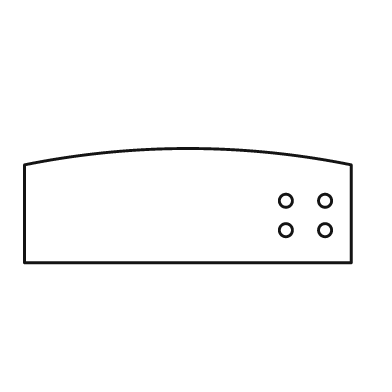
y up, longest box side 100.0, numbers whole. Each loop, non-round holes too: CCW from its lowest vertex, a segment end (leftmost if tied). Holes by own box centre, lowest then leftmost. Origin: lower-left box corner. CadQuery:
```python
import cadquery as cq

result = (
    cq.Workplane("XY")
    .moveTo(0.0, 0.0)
    .lineTo(100.0, 0.0)
    .lineTo(100.0, 30.0)
    .threePointArc((50.0, 35.0), (0.0, 30.0))
    .close()
    .moveTo(80.0, 10.0)
    .circle(2.0)
    .moveTo(92.0, 10.0)
    .circle(2.0)
    .moveTo(80.0, 19.0)
    .circle(2.0)
    .moveTo(92.0, 19.0)
    .circle(2.0)
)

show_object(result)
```